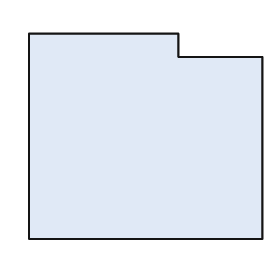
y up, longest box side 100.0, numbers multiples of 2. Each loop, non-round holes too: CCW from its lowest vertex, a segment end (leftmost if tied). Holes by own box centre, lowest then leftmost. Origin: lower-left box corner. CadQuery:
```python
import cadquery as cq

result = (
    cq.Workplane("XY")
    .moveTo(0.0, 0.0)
    .lineTo(100.0, 0.0)
    .lineTo(100.0, 78.0)
    .lineTo(64.0, 78.0)
    .lineTo(64.0, 88.0)
    .lineTo(0.0, 88.0)
    .close()
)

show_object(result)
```